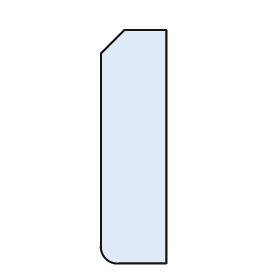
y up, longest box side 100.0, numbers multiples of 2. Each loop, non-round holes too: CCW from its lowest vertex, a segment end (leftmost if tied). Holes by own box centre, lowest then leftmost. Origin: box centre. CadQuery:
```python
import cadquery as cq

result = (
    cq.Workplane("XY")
    .moveTo(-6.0, -50.0)
    .lineTo(14.0, -50.0)
    .lineTo(14.0, 50.0)
    .lineTo(-4.0, 50.0)
    .lineTo(-14.0, 40.0)
    .lineTo(-14.0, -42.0)
    .threePointArc((-12.0, -48.0), (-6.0, -50.0))
    .close()
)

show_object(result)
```